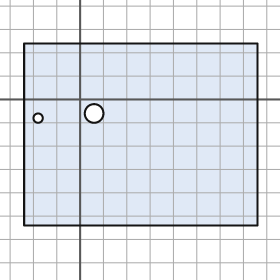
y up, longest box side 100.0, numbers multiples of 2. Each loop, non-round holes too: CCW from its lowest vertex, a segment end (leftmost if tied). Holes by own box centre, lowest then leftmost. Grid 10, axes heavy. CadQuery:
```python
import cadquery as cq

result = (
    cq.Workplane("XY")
    .moveTo(-24.0, -54.0)
    .lineTo(76.0, -54.0)
    .lineTo(76.0, 24.0)
    .lineTo(-24.0, 24.0)
    .close()
    .moveTo(-18.0, -8.0)
    .circle(2.0)
    .moveTo(6.0, -6.0)
    .circle(4.0)
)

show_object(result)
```